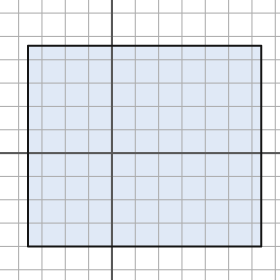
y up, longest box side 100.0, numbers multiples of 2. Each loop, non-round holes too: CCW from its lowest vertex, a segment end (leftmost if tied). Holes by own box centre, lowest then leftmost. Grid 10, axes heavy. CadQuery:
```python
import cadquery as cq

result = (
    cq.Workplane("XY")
    .moveTo(-36.0, -40.0)
    .lineTo(64.0, -40.0)
    .lineTo(64.0, 46.0)
    .lineTo(-36.0, 46.0)
    .close()
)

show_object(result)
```